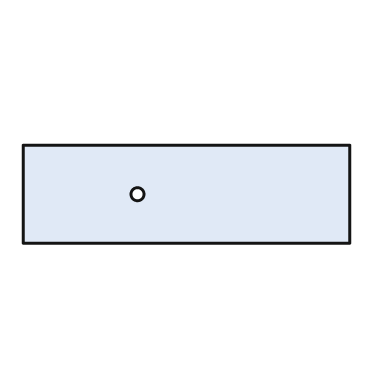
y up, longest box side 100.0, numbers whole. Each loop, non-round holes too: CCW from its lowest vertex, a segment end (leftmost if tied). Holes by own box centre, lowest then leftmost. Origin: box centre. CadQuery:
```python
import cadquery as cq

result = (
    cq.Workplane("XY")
    .moveTo(-50.0, -15.0)
    .lineTo(50.0, -15.0)
    .lineTo(50.0, 15.0)
    .lineTo(-50.0, 15.0)
    .close()
    .moveTo(-15.0, 0.0)
    .circle(2.0)
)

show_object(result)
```